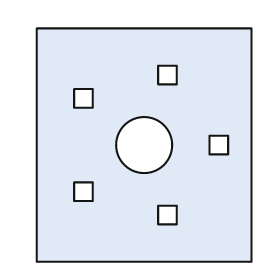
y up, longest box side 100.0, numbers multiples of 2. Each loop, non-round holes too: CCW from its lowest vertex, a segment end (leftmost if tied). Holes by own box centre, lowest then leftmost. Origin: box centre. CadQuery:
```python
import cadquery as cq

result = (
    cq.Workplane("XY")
    .moveTo(-46.0, -50.0)
    .lineTo(46.0, -50.0)
    .lineTo(46.0, 50.0)
    .lineTo(-46.0, 50.0)
    .close()
    .moveTo(6.0, -34.0)
    .lineTo(14.0, -34.0)
    .lineTo(14.0, -26.0)
    .lineTo(6.0, -26.0)
    .close()
    .moveTo(-30.0, -24.0)
    .lineTo(-22.0, -24.0)
    .lineTo(-22.0, -16.0)
    .lineTo(-30.0, -16.0)
    .close()
    .moveTo(0.0, 0.0)
    .circle(12.0)
    .moveTo(28.0, -4.0)
    .lineTo(36.0, -4.0)
    .lineTo(36.0, 4.0)
    .lineTo(28.0, 4.0)
    .close()
    .moveTo(-30.0, 16.0)
    .lineTo(-22.0, 16.0)
    .lineTo(-22.0, 24.0)
    .lineTo(-30.0, 24.0)
    .close()
    .moveTo(6.0, 26.0)
    .lineTo(14.0, 26.0)
    .lineTo(14.0, 34.0)
    .lineTo(6.0, 34.0)
    .close()
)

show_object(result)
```